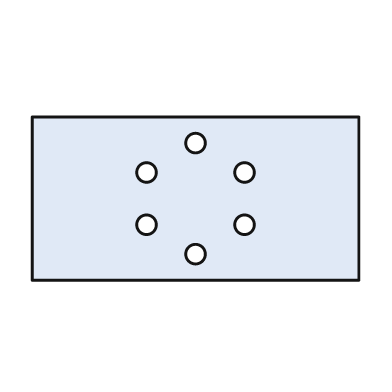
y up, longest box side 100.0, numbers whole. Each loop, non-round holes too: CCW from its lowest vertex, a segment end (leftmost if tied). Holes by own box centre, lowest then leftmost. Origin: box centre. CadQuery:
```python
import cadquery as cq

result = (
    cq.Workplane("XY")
    .moveTo(-50.0, -25.0)
    .lineTo(50.0, -25.0)
    .lineTo(50.0, 25.0)
    .lineTo(-50.0, 25.0)
    .close()
    .moveTo(0.0, -17.0)
    .circle(3.0)
    .moveTo(-15.0, -8.0)
    .circle(3.0)
    .moveTo(15.0, -8.0)
    .circle(3.0)
    .moveTo(-15.0, 8.0)
    .circle(3.0)
    .moveTo(15.0, 8.0)
    .circle(3.0)
    .moveTo(0.0, 17.0)
    .circle(3.0)
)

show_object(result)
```